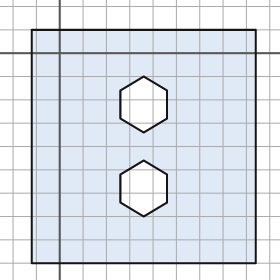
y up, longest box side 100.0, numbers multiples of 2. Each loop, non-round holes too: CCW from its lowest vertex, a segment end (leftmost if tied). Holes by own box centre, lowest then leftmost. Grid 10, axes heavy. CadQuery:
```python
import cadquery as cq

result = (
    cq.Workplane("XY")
    .moveTo(-12.0, -90.0)
    .lineTo(84.0, -90.0)
    .lineTo(84.0, 10.0)
    .lineTo(-12.0, 10.0)
    .close()
    .moveTo(36.0, -70.0)
    .lineTo(46.0, -64.0)
    .lineTo(46.0, -52.0)
    .lineTo(36.0, -46.0)
    .lineTo(26.0, -52.0)
    .lineTo(26.0, -64.0)
    .close()
    .moveTo(36.0, -34.0)
    .lineTo(46.0, -28.0)
    .lineTo(46.0, -16.0)
    .lineTo(36.0, -10.0)
    .lineTo(26.0, -16.0)
    .lineTo(26.0, -28.0)
    .close()
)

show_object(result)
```